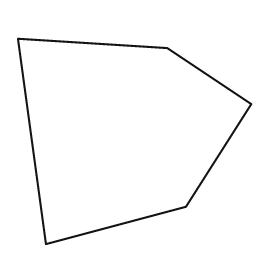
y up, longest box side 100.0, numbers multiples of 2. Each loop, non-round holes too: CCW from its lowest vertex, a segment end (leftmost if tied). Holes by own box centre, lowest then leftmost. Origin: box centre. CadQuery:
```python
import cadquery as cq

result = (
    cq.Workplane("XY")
    .moveTo(-38.0, -44.0)
    .lineTo(22.0, -28.0)
    .lineTo(50.0, 16.0)
    .lineTo(14.0, 40.0)
    .lineTo(-50.0, 44.0)
    .close()
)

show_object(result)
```